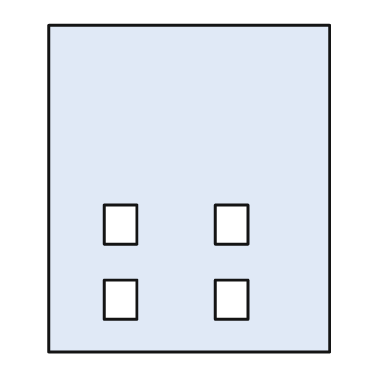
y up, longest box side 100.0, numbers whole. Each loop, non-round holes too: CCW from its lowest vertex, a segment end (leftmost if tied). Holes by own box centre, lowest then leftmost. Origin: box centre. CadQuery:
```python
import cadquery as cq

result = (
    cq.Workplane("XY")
    .moveTo(-43.0, -50.0)
    .lineTo(43.0, -50.0)
    .lineTo(43.0, 50.0)
    .lineTo(-43.0, 50.0)
    .close()
    .moveTo(-26.0, -40.0)
    .lineTo(-16.0, -40.0)
    .lineTo(-16.0, -28.0)
    .lineTo(-26.0, -28.0)
    .close()
    .moveTo(8.0, -40.0)
    .lineTo(18.0, -40.0)
    .lineTo(18.0, -28.0)
    .lineTo(8.0, -28.0)
    .close()
    .moveTo(-26.0, -17.0)
    .lineTo(-16.0, -17.0)
    .lineTo(-16.0, -5.0)
    .lineTo(-26.0, -5.0)
    .close()
    .moveTo(8.0, -17.0)
    .lineTo(18.0, -17.0)
    .lineTo(18.0, -5.0)
    .lineTo(8.0, -5.0)
    .close()
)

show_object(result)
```